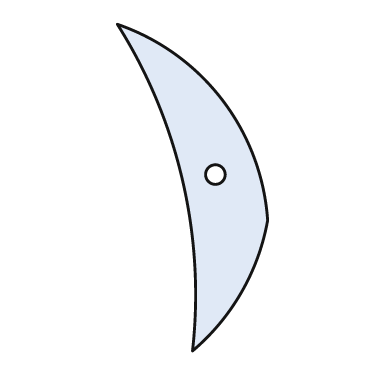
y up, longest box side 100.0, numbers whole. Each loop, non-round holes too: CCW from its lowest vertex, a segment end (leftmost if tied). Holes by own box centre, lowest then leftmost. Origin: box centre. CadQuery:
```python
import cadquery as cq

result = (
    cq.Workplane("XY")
    .moveTo(0.0, -50.0)
    .threePointArc((15.0, -32.0), (23.0, -10.0))
    .threePointArc((9.0, 27.0), (-23.0, 50.0))
    .threePointArc((-3.0, 2.0), (0.0, -50.0))
    .close()
    .moveTo(7.0, 4.0)
    .circle(3.0)
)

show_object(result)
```